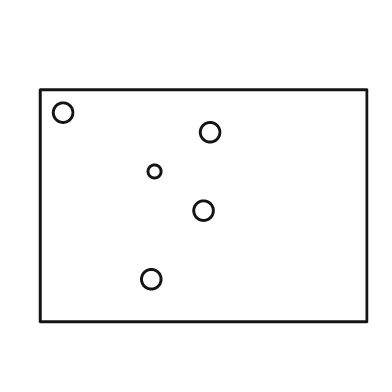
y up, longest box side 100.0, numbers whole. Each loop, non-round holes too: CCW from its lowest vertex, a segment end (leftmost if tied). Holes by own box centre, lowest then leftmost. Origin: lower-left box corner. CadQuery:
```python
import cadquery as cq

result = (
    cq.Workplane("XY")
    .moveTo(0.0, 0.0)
    .lineTo(100.0, 0.0)
    .lineTo(100.0, 71.0)
    .lineTo(0.0, 71.0)
    .close()
    .moveTo(34.0, 13.0)
    .circle(3.0)
    .moveTo(50.0, 34.0)
    .circle(3.0)
    .moveTo(35.0, 46.0)
    .circle(2.0)
    .moveTo(52.0, 58.0)
    .circle(3.0)
    .moveTo(7.0, 64.0)
    .circle(3.0)
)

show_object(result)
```